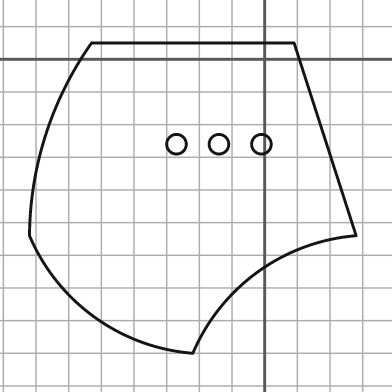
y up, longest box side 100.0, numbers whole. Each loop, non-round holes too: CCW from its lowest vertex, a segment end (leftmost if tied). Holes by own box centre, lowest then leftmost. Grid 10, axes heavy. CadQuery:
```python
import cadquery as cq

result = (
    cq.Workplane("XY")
    .moveTo(-22.0, -90.0)
    .threePointArc((-2.0, -65.0), (28.0, -54.0))
    .lineTo(9.0, 5.0)
    .lineTo(-53.0, 5.0)
    .threePointArc((-67.0, -23.0), (-72.0, -54.0))
    .threePointArc((-52.0, -79.0), (-22.0, -90.0))
    .close()
    .moveTo(-27.0, -26.0)
    .circle(3.0)
    .moveTo(-14.0, -26.0)
    .circle(3.0)
    .moveTo(-1.0, -26.0)
    .circle(3.0)
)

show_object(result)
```